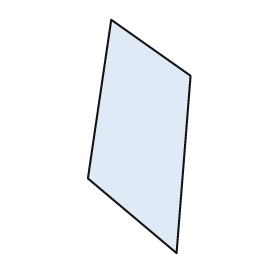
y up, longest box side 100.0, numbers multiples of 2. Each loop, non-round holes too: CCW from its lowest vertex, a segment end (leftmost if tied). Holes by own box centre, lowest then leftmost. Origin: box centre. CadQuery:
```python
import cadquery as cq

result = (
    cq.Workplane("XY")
    .moveTo(16.0, -50.0)
    .lineTo(22.0, 26.0)
    .lineTo(-12.0, 50.0)
    .lineTo(-22.0, -18.0)
    .close()
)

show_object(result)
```